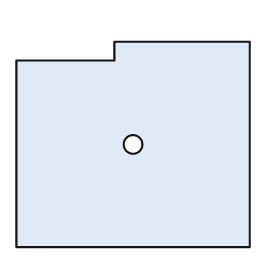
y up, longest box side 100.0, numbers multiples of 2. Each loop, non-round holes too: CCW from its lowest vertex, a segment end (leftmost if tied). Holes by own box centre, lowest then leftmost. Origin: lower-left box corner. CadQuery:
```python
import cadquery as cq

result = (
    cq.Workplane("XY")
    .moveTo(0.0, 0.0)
    .lineTo(100.0, 0.0)
    .lineTo(100.0, 88.0)
    .lineTo(42.0, 88.0)
    .lineTo(42.0, 80.0)
    .lineTo(0.0, 80.0)
    .close()
    .moveTo(50.0, 44.0)
    .circle(4.0)
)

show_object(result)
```